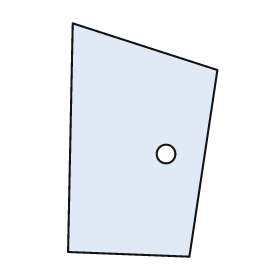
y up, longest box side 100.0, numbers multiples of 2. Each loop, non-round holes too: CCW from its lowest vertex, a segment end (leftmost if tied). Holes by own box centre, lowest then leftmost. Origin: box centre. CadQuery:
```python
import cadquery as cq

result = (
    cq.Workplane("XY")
    .moveTo(20.0, -50.0)
    .lineTo(32.0, 30.0)
    .lineTo(-30.0, 50.0)
    .lineTo(-32.0, -48.0)
    .close()
    .moveTo(10.0, -6.0)
    .circle(4.0)
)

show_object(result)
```